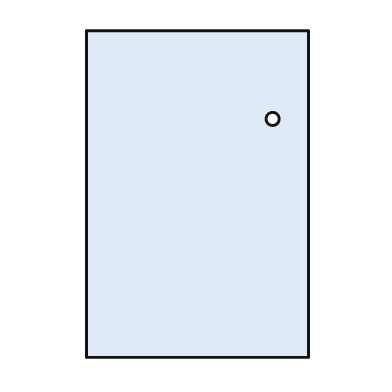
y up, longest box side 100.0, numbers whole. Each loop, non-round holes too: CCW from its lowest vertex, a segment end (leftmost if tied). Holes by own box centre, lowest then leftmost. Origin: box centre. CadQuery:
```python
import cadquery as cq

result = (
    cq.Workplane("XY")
    .moveTo(-34.0, -50.0)
    .lineTo(34.0, -50.0)
    .lineTo(34.0, 50.0)
    .lineTo(-34.0, 50.0)
    .close()
    .moveTo(23.0, 23.0)
    .circle(2.0)
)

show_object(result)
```